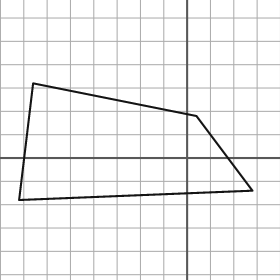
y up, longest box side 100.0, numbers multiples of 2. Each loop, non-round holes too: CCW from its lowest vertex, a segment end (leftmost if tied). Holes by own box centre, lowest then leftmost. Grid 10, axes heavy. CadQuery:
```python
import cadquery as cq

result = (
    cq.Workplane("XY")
    .moveTo(-72.0, -18.0)
    .lineTo(28.0, -14.0)
    .lineTo(4.0, 18.0)
    .lineTo(-66.0, 32.0)
    .close()
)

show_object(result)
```